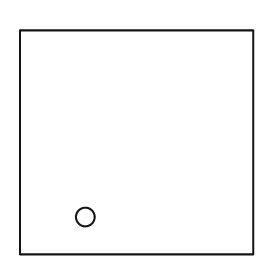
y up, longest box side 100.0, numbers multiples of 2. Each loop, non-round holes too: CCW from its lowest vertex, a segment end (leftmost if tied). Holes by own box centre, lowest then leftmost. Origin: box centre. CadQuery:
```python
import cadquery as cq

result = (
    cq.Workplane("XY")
    .moveTo(-50.0, -48.0)
    .lineTo(50.0, -48.0)
    .lineTo(50.0, 48.0)
    .lineTo(-50.0, 48.0)
    .close()
    .moveTo(-22.0, -32.0)
    .circle(4.0)
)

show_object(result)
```